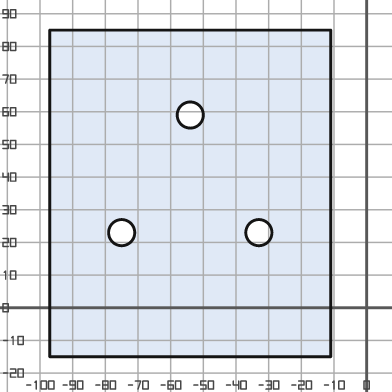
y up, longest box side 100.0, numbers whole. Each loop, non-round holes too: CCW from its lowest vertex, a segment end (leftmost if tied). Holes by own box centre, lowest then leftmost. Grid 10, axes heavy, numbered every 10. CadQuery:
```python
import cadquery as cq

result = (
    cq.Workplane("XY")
    .moveTo(-97.0, -15.0)
    .lineTo(-11.0, -15.0)
    .lineTo(-11.0, 85.0)
    .lineTo(-97.0, 85.0)
    .close()
    .moveTo(-75.0, 23.0)
    .circle(4.0)
    .moveTo(-33.0, 23.0)
    .circle(4.0)
    .moveTo(-54.0, 59.0)
    .circle(4.0)
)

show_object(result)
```